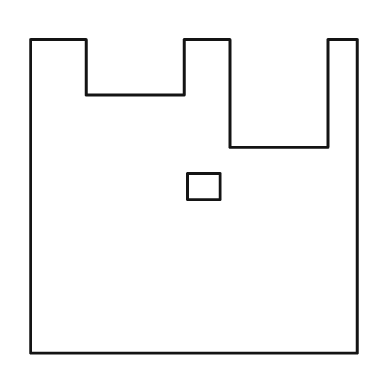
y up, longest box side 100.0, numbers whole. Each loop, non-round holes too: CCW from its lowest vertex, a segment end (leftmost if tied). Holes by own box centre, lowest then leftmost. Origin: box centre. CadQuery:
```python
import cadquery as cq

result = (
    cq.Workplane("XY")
    .moveTo(-50.0, -48.0)
    .lineTo(50.0, -48.0)
    .lineTo(50.0, 48.0)
    .lineTo(41.0, 48.0)
    .lineTo(41.0, 15.0)
    .lineTo(11.0, 15.0)
    .lineTo(11.0, 48.0)
    .lineTo(-3.0, 48.0)
    .lineTo(-3.0, 31.0)
    .lineTo(-33.0, 31.0)
    .lineTo(-33.0, 48.0)
    .lineTo(-50.0, 48.0)
    .close()
    .moveTo(-2.0, -1.0)
    .lineTo(8.0, -1.0)
    .lineTo(8.0, 7.0)
    .lineTo(-2.0, 7.0)
    .close()
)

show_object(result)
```